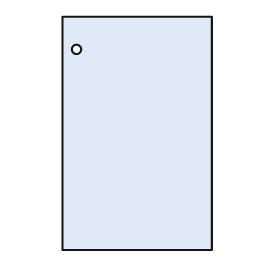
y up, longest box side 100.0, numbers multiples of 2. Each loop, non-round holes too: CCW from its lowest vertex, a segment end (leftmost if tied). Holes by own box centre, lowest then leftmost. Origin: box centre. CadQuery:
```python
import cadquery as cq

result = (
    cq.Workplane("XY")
    .moveTo(-32.0, -50.0)
    .lineTo(32.0, -50.0)
    .lineTo(32.0, 50.0)
    .lineTo(-32.0, 50.0)
    .close()
    .moveTo(-26.0, 36.0)
    .circle(2.0)
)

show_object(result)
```